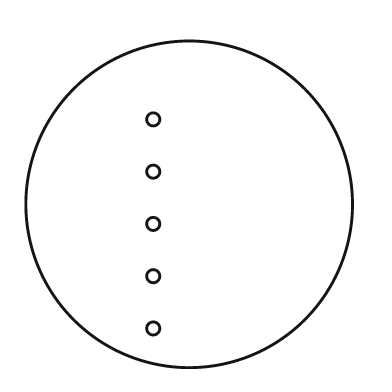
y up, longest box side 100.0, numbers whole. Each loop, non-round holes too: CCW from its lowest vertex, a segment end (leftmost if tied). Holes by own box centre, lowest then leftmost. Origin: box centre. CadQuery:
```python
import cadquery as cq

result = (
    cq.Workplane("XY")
    .moveTo(0.0, 0.0)
    .circle(50.0)
    .moveTo(-11.0, -38.0)
    .circle(2.0)
    .moveTo(-11.0, -22.0)
    .circle(2.0)
    .moveTo(-11.0, -6.0)
    .circle(2.0)
    .moveTo(-11.0, 10.0)
    .circle(2.0)
    .moveTo(-11.0, 26.0)
    .circle(2.0)
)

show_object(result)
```